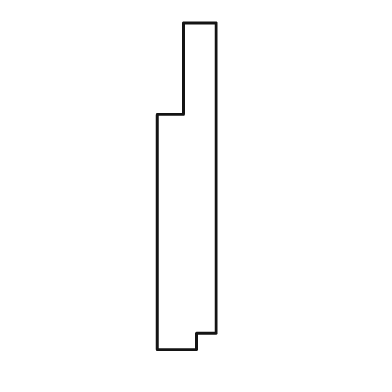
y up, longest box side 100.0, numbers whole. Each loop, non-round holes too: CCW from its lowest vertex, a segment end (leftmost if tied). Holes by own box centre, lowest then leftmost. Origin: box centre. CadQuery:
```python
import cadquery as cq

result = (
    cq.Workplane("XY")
    .moveTo(-9.0, -50.0)
    .lineTo(3.0, -50.0)
    .lineTo(3.0, -45.0)
    .lineTo(9.0, -45.0)
    .lineTo(9.0, 50.0)
    .lineTo(-1.0, 50.0)
    .lineTo(-1.0, 22.0)
    .lineTo(-9.0, 22.0)
    .close()
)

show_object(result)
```